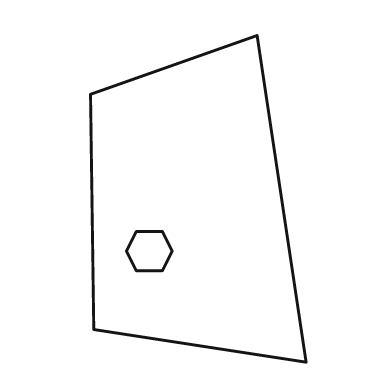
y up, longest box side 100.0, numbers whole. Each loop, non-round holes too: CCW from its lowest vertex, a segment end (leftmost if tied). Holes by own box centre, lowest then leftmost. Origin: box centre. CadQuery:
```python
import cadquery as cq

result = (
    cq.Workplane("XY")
    .moveTo(33.0, -50.0)
    .lineTo(18.0, 50.0)
    .lineTo(-33.0, 32.0)
    .lineTo(-32.0, -40.0)
    .close()
    .moveTo(-19.0, -22.0)
    .lineTo(-11.0, -22.0)
    .lineTo(-8.0, -16.0)
    .lineTo(-11.0, -10.0)
    .lineTo(-19.0, -10.0)
    .lineTo(-22.0, -16.0)
    .close()
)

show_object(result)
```